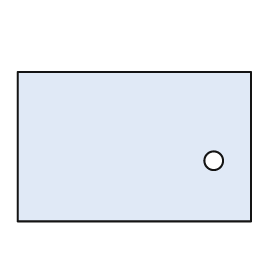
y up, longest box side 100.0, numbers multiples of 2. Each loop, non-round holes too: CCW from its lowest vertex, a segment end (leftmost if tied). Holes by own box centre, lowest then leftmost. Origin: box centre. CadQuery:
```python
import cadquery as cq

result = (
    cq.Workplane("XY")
    .moveTo(-50.0, -32.0)
    .lineTo(50.0, -32.0)
    .lineTo(50.0, 32.0)
    .lineTo(-50.0, 32.0)
    .close()
    .moveTo(34.0, -6.0)
    .circle(4.0)
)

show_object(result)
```